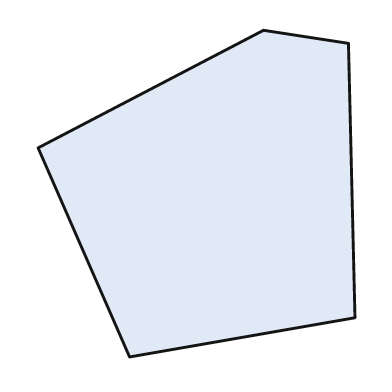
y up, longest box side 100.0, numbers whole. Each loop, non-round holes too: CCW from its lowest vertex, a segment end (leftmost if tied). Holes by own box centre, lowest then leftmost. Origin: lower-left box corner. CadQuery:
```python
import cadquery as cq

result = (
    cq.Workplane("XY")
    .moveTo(28.0, 0.0)
    .lineTo(97.0, 12.0)
    .lineTo(95.0, 96.0)
    .lineTo(69.0, 100.0)
    .lineTo(0.0, 64.0)
    .close()
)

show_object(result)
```